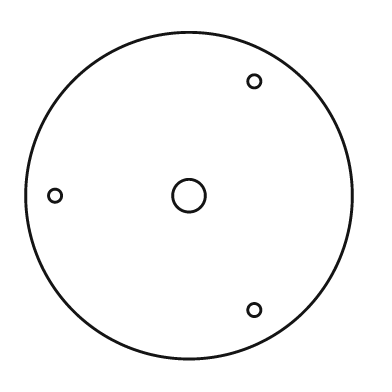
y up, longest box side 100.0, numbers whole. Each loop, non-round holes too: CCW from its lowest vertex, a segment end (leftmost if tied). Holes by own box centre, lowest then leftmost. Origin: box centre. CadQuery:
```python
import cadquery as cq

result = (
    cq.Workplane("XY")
    .moveTo(0.0, 0.0)
    .circle(50.0)
    .moveTo(20.0, -35.0)
    .circle(2.0)
    .moveTo(-41.0, 0.0)
    .circle(2.0)
    .moveTo(0.0, 0.0)
    .circle(5.0)
    .moveTo(20.0, 35.0)
    .circle(2.0)
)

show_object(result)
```